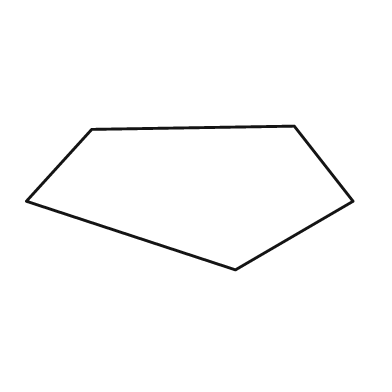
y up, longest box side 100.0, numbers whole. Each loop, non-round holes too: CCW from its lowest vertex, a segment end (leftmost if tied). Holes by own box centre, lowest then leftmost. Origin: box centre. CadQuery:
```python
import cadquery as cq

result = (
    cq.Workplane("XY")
    .moveTo(14.0, -22.0)
    .lineTo(50.0, -1.0)
    .lineTo(32.0, 22.0)
    .lineTo(-30.0, 21.0)
    .lineTo(-50.0, -1.0)
    .close()
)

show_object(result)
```